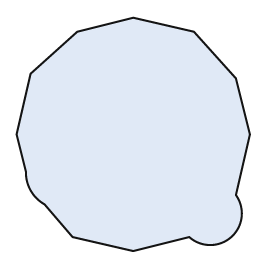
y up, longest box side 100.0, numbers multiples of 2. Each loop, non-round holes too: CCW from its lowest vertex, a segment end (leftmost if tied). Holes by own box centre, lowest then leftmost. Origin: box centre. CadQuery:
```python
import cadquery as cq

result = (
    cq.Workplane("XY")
    .moveTo(0.0, -50.0)
    .lineTo(24.0, -44.0)
    .threePointArc((42.0, -44.0), (44.0, -26.0))
    .lineTo(50.0, 0.0)
    .lineTo(44.0, 24.0)
    .lineTo(26.0, 44.0)
    .lineTo(0.0, 50.0)
    .lineTo(-24.0, 44.0)
    .lineTo(-44.0, 26.0)
    .lineTo(-50.0, 0.0)
    .lineTo(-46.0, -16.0)
    .threePointArc((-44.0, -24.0), (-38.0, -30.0))
    .lineTo(-26.0, -44.0)
    .close()
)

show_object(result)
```